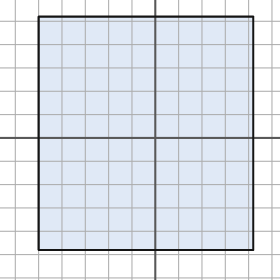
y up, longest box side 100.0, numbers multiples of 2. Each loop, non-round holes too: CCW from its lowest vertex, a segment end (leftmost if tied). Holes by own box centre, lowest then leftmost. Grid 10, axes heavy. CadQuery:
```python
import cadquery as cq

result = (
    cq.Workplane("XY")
    .moveTo(-50.0, -48.0)
    .lineTo(42.0, -48.0)
    .lineTo(42.0, 52.0)
    .lineTo(-50.0, 52.0)
    .close()
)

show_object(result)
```